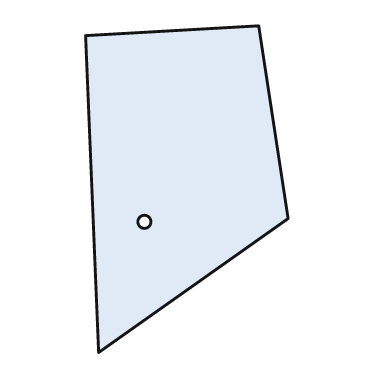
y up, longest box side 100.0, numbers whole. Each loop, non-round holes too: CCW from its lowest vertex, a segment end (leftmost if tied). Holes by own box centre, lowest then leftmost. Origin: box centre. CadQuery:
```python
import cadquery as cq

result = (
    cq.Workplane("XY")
    .moveTo(-27.0, -50.0)
    .lineTo(31.0, -9.0)
    .lineTo(22.0, 50.0)
    .lineTo(-31.0, 47.0)
    .close()
    .moveTo(-13.0, -10.0)
    .circle(2.0)
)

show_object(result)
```